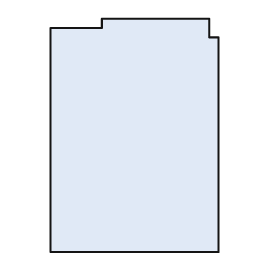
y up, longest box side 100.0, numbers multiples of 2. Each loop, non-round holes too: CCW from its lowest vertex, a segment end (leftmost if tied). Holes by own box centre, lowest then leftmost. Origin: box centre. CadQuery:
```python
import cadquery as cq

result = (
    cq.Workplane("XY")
    .moveTo(-36.0, -50.0)
    .lineTo(36.0, -50.0)
    .lineTo(36.0, 42.0)
    .lineTo(32.0, 42.0)
    .lineTo(32.0, 50.0)
    .lineTo(-14.0, 50.0)
    .lineTo(-14.0, 46.0)
    .lineTo(-36.0, 46.0)
    .close()
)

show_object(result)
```